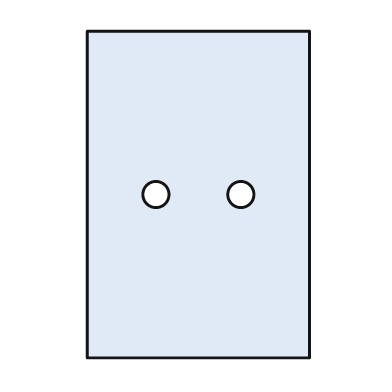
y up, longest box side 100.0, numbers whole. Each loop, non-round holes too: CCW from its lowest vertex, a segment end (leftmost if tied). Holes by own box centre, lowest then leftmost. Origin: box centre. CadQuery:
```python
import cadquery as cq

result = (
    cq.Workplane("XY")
    .moveTo(-34.0, -50.0)
    .lineTo(34.0, -50.0)
    .lineTo(34.0, 50.0)
    .lineTo(-34.0, 50.0)
    .close()
    .moveTo(-13.0, 0.0)
    .circle(4.0)
    .moveTo(13.0, 0.0)
    .circle(4.0)
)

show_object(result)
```